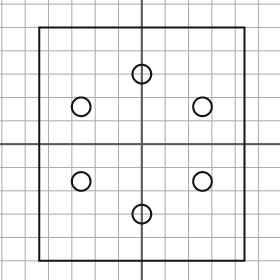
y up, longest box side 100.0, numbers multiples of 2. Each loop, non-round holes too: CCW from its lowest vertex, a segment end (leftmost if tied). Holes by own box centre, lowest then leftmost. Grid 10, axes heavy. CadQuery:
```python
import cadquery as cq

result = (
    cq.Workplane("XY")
    .moveTo(-44.0, -50.0)
    .lineTo(44.0, -50.0)
    .lineTo(44.0, 50.0)
    .lineTo(-44.0, 50.0)
    .close()
    .moveTo(0.0, -30.0)
    .circle(4.0)
    .moveTo(-26.0, -16.0)
    .circle(4.0)
    .moveTo(26.0, -16.0)
    .circle(4.0)
    .moveTo(-26.0, 16.0)
    .circle(4.0)
    .moveTo(26.0, 16.0)
    .circle(4.0)
    .moveTo(0.0, 30.0)
    .circle(4.0)
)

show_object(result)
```